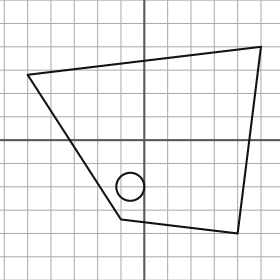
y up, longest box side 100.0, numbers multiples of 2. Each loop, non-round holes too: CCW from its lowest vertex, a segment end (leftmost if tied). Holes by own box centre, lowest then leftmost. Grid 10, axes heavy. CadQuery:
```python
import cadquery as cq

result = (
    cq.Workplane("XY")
    .moveTo(40.0, -40.0)
    .lineTo(50.0, 40.0)
    .lineTo(-50.0, 28.0)
    .lineTo(-10.0, -34.0)
    .close()
    .moveTo(-6.0, -20.0)
    .circle(6.0)
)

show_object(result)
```